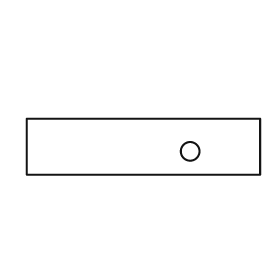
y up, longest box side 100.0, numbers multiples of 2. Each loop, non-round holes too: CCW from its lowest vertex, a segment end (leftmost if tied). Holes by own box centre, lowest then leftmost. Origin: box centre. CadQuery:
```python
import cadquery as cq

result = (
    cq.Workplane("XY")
    .moveTo(-50.0, -12.0)
    .lineTo(50.0, -12.0)
    .lineTo(50.0, 12.0)
    .lineTo(-50.0, 12.0)
    .close()
    .moveTo(20.0, -2.0)
    .circle(4.0)
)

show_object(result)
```